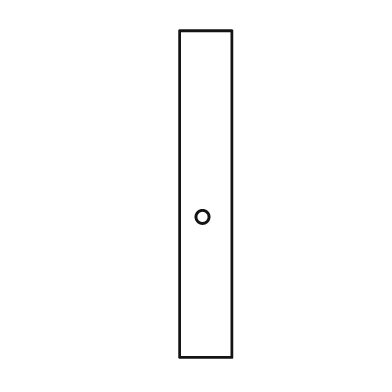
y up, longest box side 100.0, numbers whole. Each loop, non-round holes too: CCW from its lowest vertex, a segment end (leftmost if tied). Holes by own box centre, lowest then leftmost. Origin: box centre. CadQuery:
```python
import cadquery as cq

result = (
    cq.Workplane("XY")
    .moveTo(-8.0, -50.0)
    .lineTo(8.0, -50.0)
    .lineTo(8.0, 50.0)
    .lineTo(-8.0, 50.0)
    .close()
    .moveTo(-1.0, -7.0)
    .circle(2.0)
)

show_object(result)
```